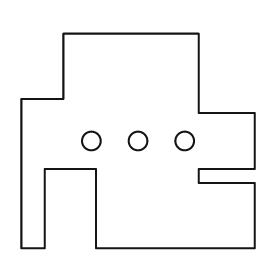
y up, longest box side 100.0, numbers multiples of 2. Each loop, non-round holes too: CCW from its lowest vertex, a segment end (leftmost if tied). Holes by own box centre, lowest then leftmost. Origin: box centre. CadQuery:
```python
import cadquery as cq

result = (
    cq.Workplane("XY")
    .moveTo(-50.0, -46.0)
    .lineTo(-40.0, -46.0)
    .lineTo(-40.0, -12.0)
    .lineTo(-18.0, -12.0)
    .lineTo(-18.0, -46.0)
    .lineTo(50.0, -46.0)
    .lineTo(50.0, -18.0)
    .lineTo(26.0, -18.0)
    .lineTo(26.0, -12.0)
    .lineTo(50.0, -12.0)
    .lineTo(50.0, 12.0)
    .lineTo(26.0, 12.0)
    .lineTo(26.0, 46.0)
    .lineTo(-32.0, 46.0)
    .lineTo(-32.0, 18.0)
    .lineTo(-50.0, 18.0)
    .close()
    .moveTo(-20.0, 0.0)
    .circle(4.0)
    .moveTo(0.0, 0.0)
    .circle(4.0)
    .moveTo(20.0, 0.0)
    .circle(4.0)
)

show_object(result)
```